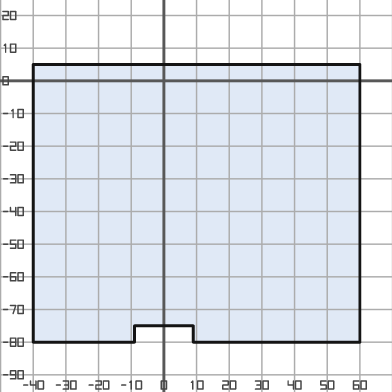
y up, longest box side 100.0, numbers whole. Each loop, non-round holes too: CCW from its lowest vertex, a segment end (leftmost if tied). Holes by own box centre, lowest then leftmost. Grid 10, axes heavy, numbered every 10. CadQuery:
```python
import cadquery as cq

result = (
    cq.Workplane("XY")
    .moveTo(-40.0, -80.0)
    .lineTo(-9.0, -80.0)
    .lineTo(-9.0, -75.0)
    .lineTo(9.0, -75.0)
    .lineTo(9.0, -80.0)
    .lineTo(60.0, -80.0)
    .lineTo(60.0, 5.0)
    .lineTo(-40.0, 5.0)
    .close()
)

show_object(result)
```